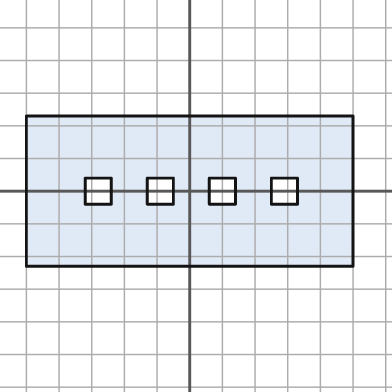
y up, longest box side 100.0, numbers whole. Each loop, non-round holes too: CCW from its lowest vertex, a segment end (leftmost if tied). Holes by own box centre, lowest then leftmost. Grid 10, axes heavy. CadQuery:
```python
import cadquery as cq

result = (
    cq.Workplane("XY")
    .moveTo(-50.0, -23.0)
    .lineTo(50.0, -23.0)
    .lineTo(50.0, 23.0)
    .lineTo(-50.0, 23.0)
    .close()
    .moveTo(-32.0, -4.0)
    .lineTo(-24.0, -4.0)
    .lineTo(-24.0, 4.0)
    .lineTo(-32.0, 4.0)
    .close()
    .moveTo(-13.0, -4.0)
    .lineTo(-5.0, -4.0)
    .lineTo(-5.0, 4.0)
    .lineTo(-13.0, 4.0)
    .close()
    .moveTo(6.0, -4.0)
    .lineTo(14.0, -4.0)
    .lineTo(14.0, 4.0)
    .lineTo(6.0, 4.0)
    .close()
    .moveTo(25.0, -4.0)
    .lineTo(33.0, -4.0)
    .lineTo(33.0, 4.0)
    .lineTo(25.0, 4.0)
    .close()
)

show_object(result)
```